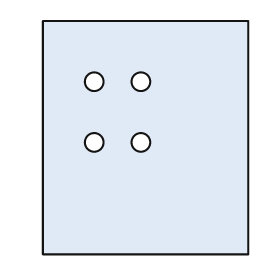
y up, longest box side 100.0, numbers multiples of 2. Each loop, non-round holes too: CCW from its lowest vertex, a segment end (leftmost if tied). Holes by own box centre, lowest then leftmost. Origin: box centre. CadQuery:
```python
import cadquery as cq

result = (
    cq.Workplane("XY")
    .moveTo(-44.0, -50.0)
    .lineTo(44.0, -50.0)
    .lineTo(44.0, 50.0)
    .lineTo(-44.0, 50.0)
    .close()
    .moveTo(-22.0, -2.0)
    .circle(4.0)
    .moveTo(-2.0, -2.0)
    .circle(4.0)
    .moveTo(-22.0, 24.0)
    .circle(4.0)
    .moveTo(-2.0, 24.0)
    .circle(4.0)
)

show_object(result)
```